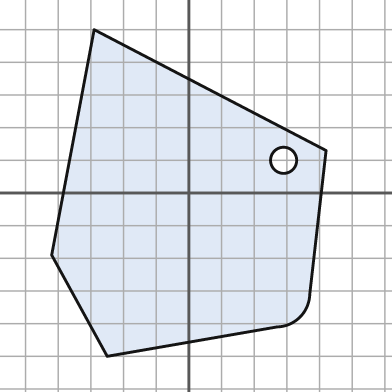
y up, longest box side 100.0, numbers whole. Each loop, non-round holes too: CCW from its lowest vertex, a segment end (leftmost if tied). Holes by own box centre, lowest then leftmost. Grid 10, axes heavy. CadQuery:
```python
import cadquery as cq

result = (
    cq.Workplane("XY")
    .moveTo(-25.0, -50.0)
    .lineTo(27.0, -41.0)
    .threePointArc((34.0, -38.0), (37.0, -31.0))
    .lineTo(42.0, 13.0)
    .lineTo(-29.0, 50.0)
    .lineTo(-42.0, -19.0)
    .close()
    .moveTo(29.0, 10.0)
    .circle(4.0)
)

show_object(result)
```